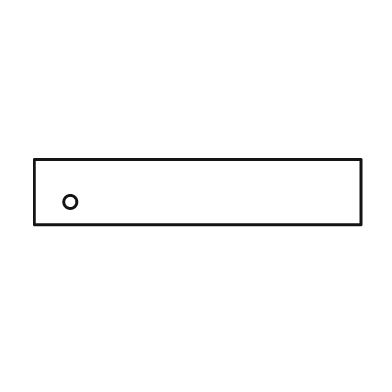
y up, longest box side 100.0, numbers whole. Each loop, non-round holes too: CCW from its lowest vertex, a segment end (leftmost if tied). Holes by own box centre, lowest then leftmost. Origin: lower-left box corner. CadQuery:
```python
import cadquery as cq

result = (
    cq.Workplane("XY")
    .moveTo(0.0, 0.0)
    .lineTo(100.0, 0.0)
    .lineTo(100.0, 20.0)
    .lineTo(0.0, 20.0)
    .close()
    .moveTo(11.0, 7.0)
    .circle(2.0)
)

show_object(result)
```